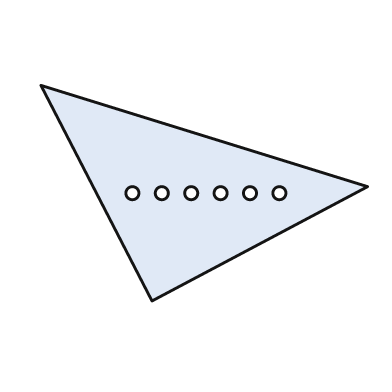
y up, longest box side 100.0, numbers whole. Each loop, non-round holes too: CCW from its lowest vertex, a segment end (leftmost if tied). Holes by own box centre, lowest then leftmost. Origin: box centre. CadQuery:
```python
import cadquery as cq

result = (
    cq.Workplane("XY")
    .moveTo(-16.0, -33.0)
    .lineTo(50.0, 2.0)
    .lineTo(-50.0, 33.0)
    .close()
    .moveTo(-22.0, 0.0)
    .circle(2.0)
    .moveTo(-13.0, 0.0)
    .circle(2.0)
    .moveTo(-4.0, 0.0)
    .circle(2.0)
    .moveTo(5.0, 0.0)
    .circle(2.0)
    .moveTo(14.0, 0.0)
    .circle(2.0)
    .moveTo(23.0, 0.0)
    .circle(2.0)
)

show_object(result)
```